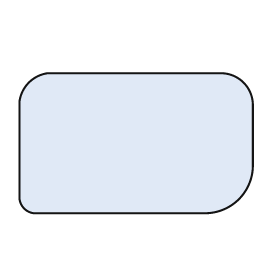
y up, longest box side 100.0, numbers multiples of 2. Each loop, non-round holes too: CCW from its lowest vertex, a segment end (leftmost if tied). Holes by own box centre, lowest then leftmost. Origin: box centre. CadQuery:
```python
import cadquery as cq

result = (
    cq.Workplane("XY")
    .moveTo(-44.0, -30.0)
    .lineTo(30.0, -30.0)
    .threePointArc((44.0, -24.0), (50.0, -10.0))
    .lineTo(50.0, 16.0)
    .threePointArc((46.0, 26.0), (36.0, 30.0))
    .lineTo(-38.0, 30.0)
    .threePointArc((-46.0, 26.0), (-50.0, 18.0))
    .lineTo(-50.0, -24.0)
    .threePointArc((-48.0, -28.0), (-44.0, -30.0))
    .close()
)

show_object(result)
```